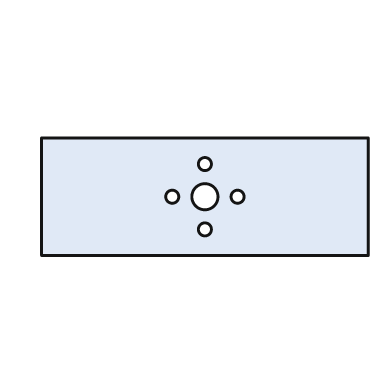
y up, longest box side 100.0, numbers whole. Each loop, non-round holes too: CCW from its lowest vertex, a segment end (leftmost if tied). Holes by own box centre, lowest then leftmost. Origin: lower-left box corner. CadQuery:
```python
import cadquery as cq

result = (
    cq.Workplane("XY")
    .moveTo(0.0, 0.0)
    .lineTo(100.0, 0.0)
    .lineTo(100.0, 36.0)
    .lineTo(0.0, 36.0)
    .close()
    .moveTo(50.0, 8.0)
    .circle(2.0)
    .moveTo(40.0, 18.0)
    .circle(2.0)
    .moveTo(50.0, 18.0)
    .circle(4.0)
    .moveTo(60.0, 18.0)
    .circle(2.0)
    .moveTo(50.0, 28.0)
    .circle(2.0)
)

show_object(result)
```